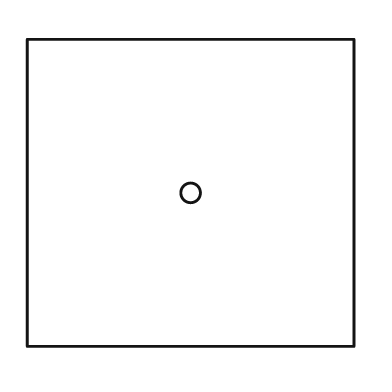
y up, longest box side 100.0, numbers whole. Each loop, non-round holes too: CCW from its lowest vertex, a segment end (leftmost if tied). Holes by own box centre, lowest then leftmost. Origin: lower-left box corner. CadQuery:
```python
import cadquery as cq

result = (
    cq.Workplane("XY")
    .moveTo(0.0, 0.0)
    .lineTo(100.0, 0.0)
    .lineTo(100.0, 94.0)
    .lineTo(0.0, 94.0)
    .close()
    .moveTo(50.0, 47.0)
    .circle(3.0)
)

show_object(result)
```